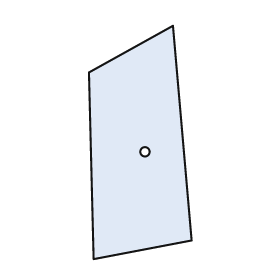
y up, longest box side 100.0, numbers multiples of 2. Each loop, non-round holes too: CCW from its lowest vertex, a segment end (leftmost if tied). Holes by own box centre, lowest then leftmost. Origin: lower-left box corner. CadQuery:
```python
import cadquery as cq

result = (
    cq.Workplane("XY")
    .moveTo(2.0, 0.0)
    .lineTo(44.0, 8.0)
    .lineTo(36.0, 100.0)
    .lineTo(0.0, 80.0)
    .close()
    .moveTo(24.0, 46.0)
    .circle(2.0)
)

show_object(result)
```